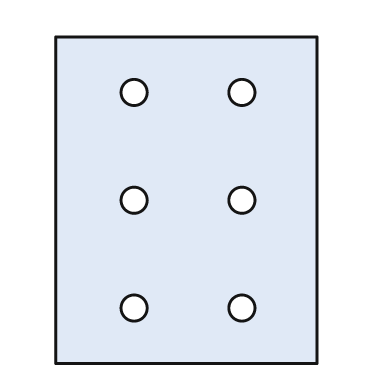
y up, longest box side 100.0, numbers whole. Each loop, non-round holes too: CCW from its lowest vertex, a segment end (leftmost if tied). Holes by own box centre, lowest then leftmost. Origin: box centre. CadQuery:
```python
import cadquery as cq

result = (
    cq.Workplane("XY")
    .moveTo(-40.0, -50.0)
    .lineTo(40.0, -50.0)
    .lineTo(40.0, 50.0)
    .lineTo(-40.0, 50.0)
    .close()
    .moveTo(-16.0, -33.0)
    .circle(4.0)
    .moveTo(17.0, -33.0)
    .circle(4.0)
    .moveTo(-16.0, 0.0)
    .circle(4.0)
    .moveTo(17.0, 0.0)
    .circle(4.0)
    .moveTo(-16.0, 33.0)
    .circle(4.0)
    .moveTo(17.0, 33.0)
    .circle(4.0)
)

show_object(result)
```